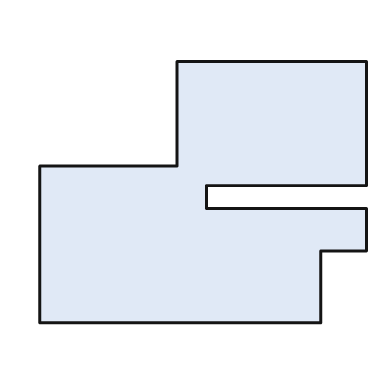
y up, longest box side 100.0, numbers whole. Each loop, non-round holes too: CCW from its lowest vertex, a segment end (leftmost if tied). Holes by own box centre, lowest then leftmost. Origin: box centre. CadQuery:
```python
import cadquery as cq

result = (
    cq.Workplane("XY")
    .moveTo(-50.0, -40.0)
    .lineTo(36.0, -40.0)
    .lineTo(36.0, -18.0)
    .lineTo(50.0, -18.0)
    .lineTo(50.0, -5.0)
    .lineTo(1.0, -5.0)
    .lineTo(1.0, 2.0)
    .lineTo(50.0, 2.0)
    .lineTo(50.0, 40.0)
    .lineTo(-8.0, 40.0)
    .lineTo(-8.0, 8.0)
    .lineTo(-50.0, 8.0)
    .close()
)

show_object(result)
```